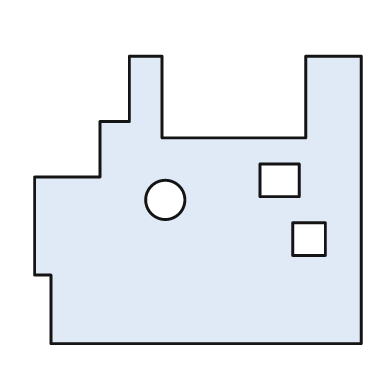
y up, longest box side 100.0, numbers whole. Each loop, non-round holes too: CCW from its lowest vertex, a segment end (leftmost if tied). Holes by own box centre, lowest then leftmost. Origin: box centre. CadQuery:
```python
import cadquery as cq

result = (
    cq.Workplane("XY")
    .moveTo(-45.0, -44.0)
    .lineTo(50.0, -44.0)
    .lineTo(50.0, 44.0)
    .lineTo(33.0, 44.0)
    .lineTo(33.0, 19.0)
    .lineTo(-11.0, 19.0)
    .lineTo(-11.0, 44.0)
    .lineTo(-21.0, 44.0)
    .lineTo(-21.0, 24.0)
    .lineTo(-30.0, 24.0)
    .lineTo(-30.0, 7.0)
    .lineTo(-50.0, 7.0)
    .lineTo(-50.0, -23.0)
    .lineTo(-45.0, -23.0)
    .close()
    .moveTo(29.0, -17.0)
    .lineTo(39.0, -17.0)
    .lineTo(39.0, -7.0)
    .lineTo(29.0, -7.0)
    .close()
    .moveTo(-10.0, 0.0)
    .circle(6.0)
    .moveTo(19.0, 1.0)
    .lineTo(31.0, 1.0)
    .lineTo(31.0, 11.0)
    .lineTo(19.0, 11.0)
    .close()
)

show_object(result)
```